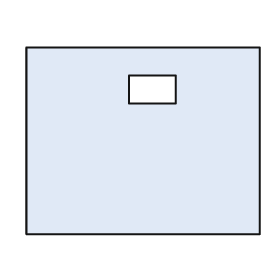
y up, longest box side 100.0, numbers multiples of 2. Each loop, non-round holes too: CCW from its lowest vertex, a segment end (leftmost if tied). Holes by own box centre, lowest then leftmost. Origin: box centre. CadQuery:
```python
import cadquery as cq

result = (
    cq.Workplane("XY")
    .moveTo(-50.0, -40.0)
    .lineTo(50.0, -40.0)
    .lineTo(50.0, 40.0)
    .lineTo(-50.0, 40.0)
    .close()
    .moveTo(-6.0, 16.0)
    .lineTo(14.0, 16.0)
    .lineTo(14.0, 28.0)
    .lineTo(-6.0, 28.0)
    .close()
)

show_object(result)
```